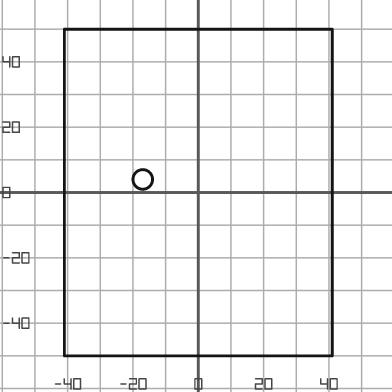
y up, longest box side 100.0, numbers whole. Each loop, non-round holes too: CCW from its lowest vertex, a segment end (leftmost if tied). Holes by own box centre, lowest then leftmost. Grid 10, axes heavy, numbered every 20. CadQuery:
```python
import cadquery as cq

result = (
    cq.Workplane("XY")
    .moveTo(-41.0, -50.0)
    .lineTo(41.0, -50.0)
    .lineTo(41.0, 50.0)
    .lineTo(-41.0, 50.0)
    .close()
    .moveTo(-17.0, 4.0)
    .circle(3.0)
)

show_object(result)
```